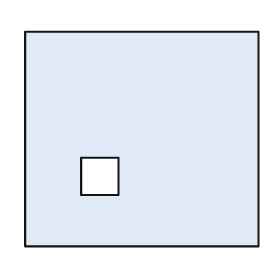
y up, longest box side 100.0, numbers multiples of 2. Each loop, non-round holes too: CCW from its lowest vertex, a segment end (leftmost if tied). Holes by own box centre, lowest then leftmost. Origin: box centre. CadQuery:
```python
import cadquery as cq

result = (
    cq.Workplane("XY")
    .moveTo(-50.0, -46.0)
    .lineTo(50.0, -46.0)
    .lineTo(50.0, 46.0)
    .lineTo(-50.0, 46.0)
    .close()
    .moveTo(-26.0, -24.0)
    .lineTo(-10.0, -24.0)
    .lineTo(-10.0, -8.0)
    .lineTo(-26.0, -8.0)
    .close()
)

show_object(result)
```